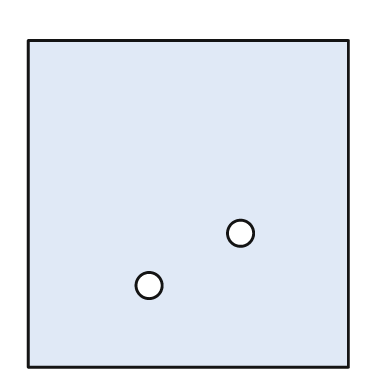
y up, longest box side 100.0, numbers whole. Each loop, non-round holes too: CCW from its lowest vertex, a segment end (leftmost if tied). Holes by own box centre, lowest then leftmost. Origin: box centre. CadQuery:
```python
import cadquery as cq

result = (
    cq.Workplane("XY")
    .moveTo(-49.0, -50.0)
    .lineTo(49.0, -50.0)
    .lineTo(49.0, 50.0)
    .lineTo(-49.0, 50.0)
    .close()
    .moveTo(-12.0, -25.0)
    .circle(4.0)
    .moveTo(16.0, -9.0)
    .circle(4.0)
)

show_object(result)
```